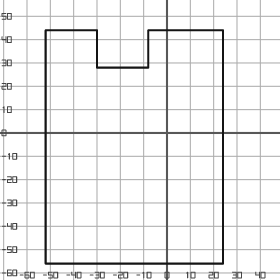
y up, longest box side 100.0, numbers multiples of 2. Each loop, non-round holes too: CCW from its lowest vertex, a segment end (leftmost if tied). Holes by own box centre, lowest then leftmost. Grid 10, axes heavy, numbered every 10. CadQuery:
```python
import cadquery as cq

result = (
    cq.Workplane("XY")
    .moveTo(-52.0, -56.0)
    .lineTo(24.0, -56.0)
    .lineTo(24.0, 44.0)
    .lineTo(-8.0, 44.0)
    .lineTo(-8.0, 28.0)
    .lineTo(-30.0, 28.0)
    .lineTo(-30.0, 44.0)
    .lineTo(-52.0, 44.0)
    .close()
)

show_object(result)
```